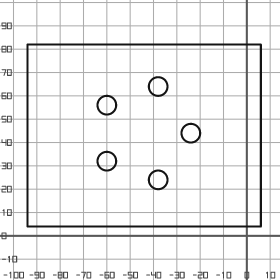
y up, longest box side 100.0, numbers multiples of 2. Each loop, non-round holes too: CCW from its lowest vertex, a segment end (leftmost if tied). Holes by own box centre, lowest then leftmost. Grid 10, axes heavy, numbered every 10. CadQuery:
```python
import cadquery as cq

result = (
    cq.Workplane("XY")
    .moveTo(-94.0, 4.0)
    .lineTo(6.0, 4.0)
    .lineTo(6.0, 82.0)
    .lineTo(-94.0, 82.0)
    .close()
    .moveTo(-38.0, 24.0)
    .circle(4.0)
    .moveTo(-60.0, 32.0)
    .circle(4.0)
    .moveTo(-24.0, 44.0)
    .circle(4.0)
    .moveTo(-60.0, 56.0)
    .circle(4.0)
    .moveTo(-38.0, 64.0)
    .circle(4.0)
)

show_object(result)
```